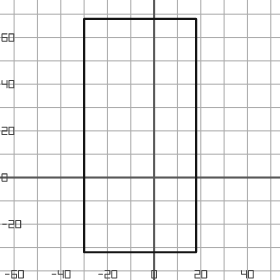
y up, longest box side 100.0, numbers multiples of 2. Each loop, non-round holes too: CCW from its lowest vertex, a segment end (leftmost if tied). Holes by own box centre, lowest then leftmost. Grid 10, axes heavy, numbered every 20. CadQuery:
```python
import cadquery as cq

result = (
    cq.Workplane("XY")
    .moveTo(-30.0, -32.0)
    .lineTo(18.0, -32.0)
    .lineTo(18.0, 68.0)
    .lineTo(-30.0, 68.0)
    .close()
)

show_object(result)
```